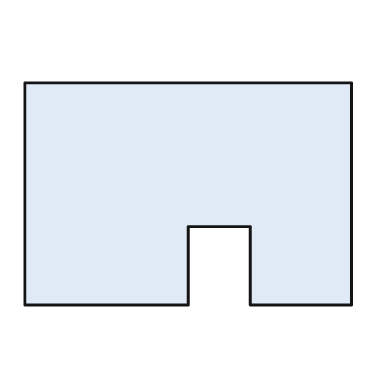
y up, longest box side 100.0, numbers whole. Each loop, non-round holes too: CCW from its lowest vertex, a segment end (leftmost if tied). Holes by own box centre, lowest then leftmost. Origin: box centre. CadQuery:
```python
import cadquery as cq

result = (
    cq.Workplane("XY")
    .moveTo(-50.0, -34.0)
    .lineTo(0.0, -34.0)
    .lineTo(0.0, -10.0)
    .lineTo(19.0, -10.0)
    .lineTo(19.0, -34.0)
    .lineTo(50.0, -34.0)
    .lineTo(50.0, 34.0)
    .lineTo(-50.0, 34.0)
    .close()
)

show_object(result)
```